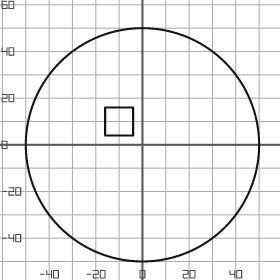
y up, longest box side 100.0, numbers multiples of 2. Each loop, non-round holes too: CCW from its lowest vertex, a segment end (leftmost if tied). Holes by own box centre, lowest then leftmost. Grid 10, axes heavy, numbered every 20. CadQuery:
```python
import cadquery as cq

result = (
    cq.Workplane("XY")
    .moveTo(0.0, 0.0)
    .circle(50.0)
    .moveTo(-16.0, 4.0)
    .lineTo(-4.0, 4.0)
    .lineTo(-4.0, 16.0)
    .lineTo(-16.0, 16.0)
    .close()
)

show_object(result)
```